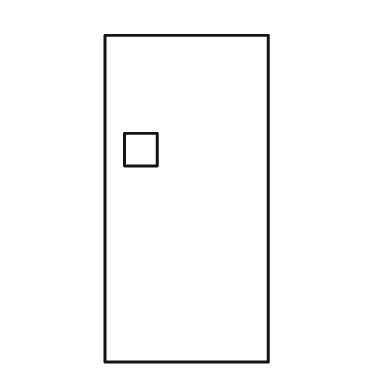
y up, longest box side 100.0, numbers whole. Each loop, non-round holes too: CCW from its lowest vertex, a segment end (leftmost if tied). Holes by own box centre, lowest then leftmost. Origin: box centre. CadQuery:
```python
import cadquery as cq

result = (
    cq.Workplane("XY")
    .moveTo(-25.0, -50.0)
    .lineTo(25.0, -50.0)
    .lineTo(25.0, 50.0)
    .lineTo(-25.0, 50.0)
    .close()
    .moveTo(-19.0, 10.0)
    .lineTo(-9.0, 10.0)
    .lineTo(-9.0, 20.0)
    .lineTo(-19.0, 20.0)
    .close()
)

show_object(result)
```